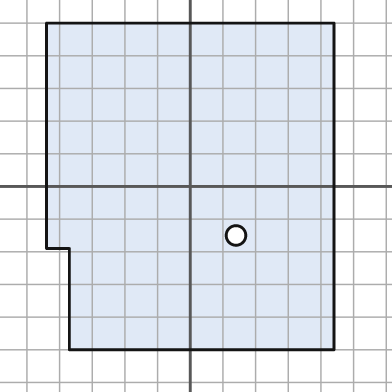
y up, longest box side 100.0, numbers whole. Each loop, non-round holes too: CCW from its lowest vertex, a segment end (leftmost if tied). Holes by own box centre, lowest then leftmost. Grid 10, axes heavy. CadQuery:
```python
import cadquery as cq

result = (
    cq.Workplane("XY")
    .moveTo(-37.0, -50.0)
    .lineTo(44.0, -50.0)
    .lineTo(44.0, 50.0)
    .lineTo(-44.0, 50.0)
    .lineTo(-44.0, -19.0)
    .lineTo(-37.0, -19.0)
    .close()
    .moveTo(14.0, -15.0)
    .circle(3.0)
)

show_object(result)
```